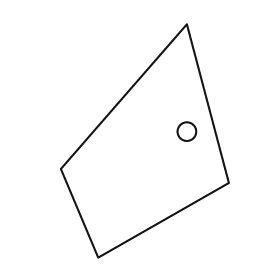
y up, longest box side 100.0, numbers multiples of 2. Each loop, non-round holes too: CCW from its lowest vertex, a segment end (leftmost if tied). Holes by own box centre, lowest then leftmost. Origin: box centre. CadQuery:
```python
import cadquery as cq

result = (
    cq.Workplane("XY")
    .moveTo(-20.0, -50.0)
    .lineTo(36.0, -18.0)
    .lineTo(18.0, 50.0)
    .lineTo(-36.0, -12.0)
    .close()
    .moveTo(18.0, 4.0)
    .circle(4.0)
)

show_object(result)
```